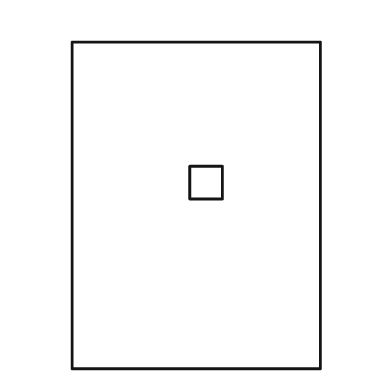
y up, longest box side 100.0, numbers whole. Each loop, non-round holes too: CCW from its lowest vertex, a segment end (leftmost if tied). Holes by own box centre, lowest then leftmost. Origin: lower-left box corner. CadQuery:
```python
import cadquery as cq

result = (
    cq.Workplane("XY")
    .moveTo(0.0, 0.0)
    .lineTo(76.0, 0.0)
    .lineTo(76.0, 100.0)
    .lineTo(0.0, 100.0)
    .close()
    .moveTo(36.0, 52.0)
    .lineTo(46.0, 52.0)
    .lineTo(46.0, 62.0)
    .lineTo(36.0, 62.0)
    .close()
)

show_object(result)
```